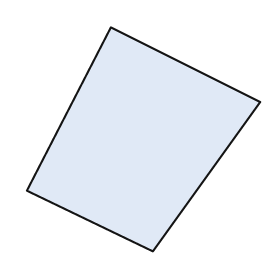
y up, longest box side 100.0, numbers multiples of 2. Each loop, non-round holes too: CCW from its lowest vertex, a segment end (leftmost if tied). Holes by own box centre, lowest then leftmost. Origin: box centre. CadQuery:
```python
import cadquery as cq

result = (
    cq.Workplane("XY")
    .moveTo(4.0, -48.0)
    .lineTo(50.0, 16.0)
    .lineTo(-14.0, 48.0)
    .lineTo(-50.0, -22.0)
    .close()
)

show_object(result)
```